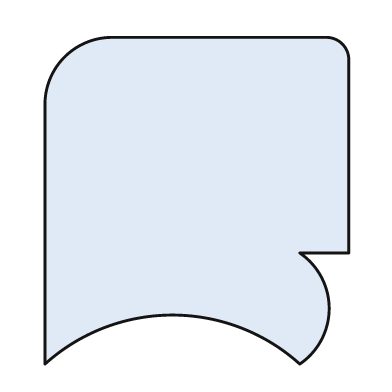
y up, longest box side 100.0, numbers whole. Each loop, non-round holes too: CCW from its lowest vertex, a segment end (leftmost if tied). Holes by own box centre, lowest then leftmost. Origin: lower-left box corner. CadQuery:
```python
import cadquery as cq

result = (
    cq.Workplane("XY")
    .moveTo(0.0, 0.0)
    .threePointArc((39.0, 15.0), (78.0, 0.0))
    .threePointArc((87.0, 17.0), (78.0, 34.0))
    .lineTo(93.0, 34.0)
    .lineTo(93.0, 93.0)
    .threePointArc((91.0, 98.0), (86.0, 100.0))
    .lineTo(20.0, 100.0)
    .threePointArc((6.0, 94.0), (0.0, 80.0))
    .close()
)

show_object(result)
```